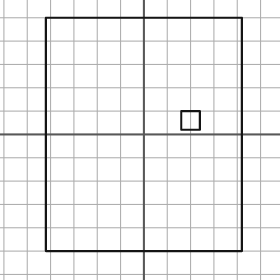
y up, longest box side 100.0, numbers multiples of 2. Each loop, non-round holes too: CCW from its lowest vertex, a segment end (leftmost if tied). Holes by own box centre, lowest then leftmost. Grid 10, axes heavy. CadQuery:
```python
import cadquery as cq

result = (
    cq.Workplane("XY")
    .moveTo(-42.0, -50.0)
    .lineTo(42.0, -50.0)
    .lineTo(42.0, 50.0)
    .lineTo(-42.0, 50.0)
    .close()
    .moveTo(16.0, 2.0)
    .lineTo(24.0, 2.0)
    .lineTo(24.0, 10.0)
    .lineTo(16.0, 10.0)
    .close()
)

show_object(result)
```